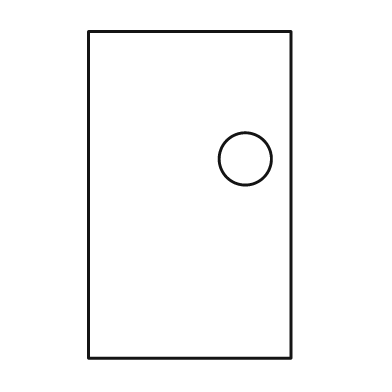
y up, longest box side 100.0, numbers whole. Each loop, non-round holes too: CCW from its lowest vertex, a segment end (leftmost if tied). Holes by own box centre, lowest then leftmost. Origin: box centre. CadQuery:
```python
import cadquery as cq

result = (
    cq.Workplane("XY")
    .moveTo(-31.0, -50.0)
    .lineTo(31.0, -50.0)
    .lineTo(31.0, 50.0)
    .lineTo(-31.0, 50.0)
    .close()
    .moveTo(17.0, 11.0)
    .circle(8.0)
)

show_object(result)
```